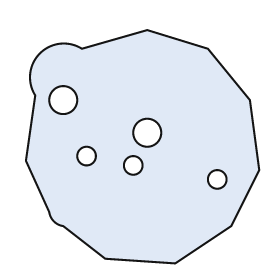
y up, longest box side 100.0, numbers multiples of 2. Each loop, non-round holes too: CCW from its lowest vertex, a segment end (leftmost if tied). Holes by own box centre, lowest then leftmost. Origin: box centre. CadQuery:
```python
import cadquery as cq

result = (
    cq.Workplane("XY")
    .moveTo(14.0, -50.0)
    .lineTo(38.0, -34.0)
    .lineTo(50.0, -10.0)
    .lineTo(46.0, 20.0)
    .lineTo(28.0, 42.0)
    .lineTo(2.0, 50.0)
    .lineTo(-26.0, 42.0)
    .threePointArc((-44.0, 40.0), (-46.0, 22.0))
    .lineTo(-50.0, -6.0)
    .lineTo(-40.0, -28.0)
    .threePointArc((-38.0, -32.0), (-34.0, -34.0))
    .lineTo(-16.0, -48.0)
    .close()
    .moveTo(32.0, -14.0)
    .circle(4.0)
    .moveTo(-4.0, -8.0)
    .circle(4.0)
    .moveTo(-24.0, -4.0)
    .circle(4.0)
    .moveTo(2.0, 6.0)
    .circle(6.0)
    .moveTo(-34.0, 20.0)
    .circle(6.0)
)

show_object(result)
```